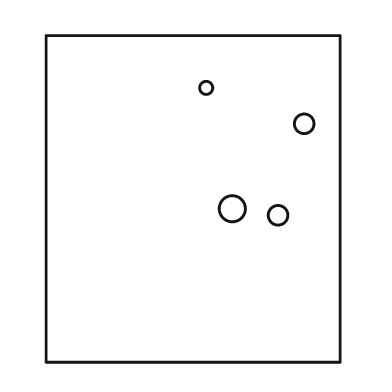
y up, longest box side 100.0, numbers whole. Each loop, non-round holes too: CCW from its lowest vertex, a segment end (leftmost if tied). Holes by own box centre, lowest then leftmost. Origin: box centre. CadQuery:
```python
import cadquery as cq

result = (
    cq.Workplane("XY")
    .moveTo(-45.0, -50.0)
    .lineTo(45.0, -50.0)
    .lineTo(45.0, 50.0)
    .lineTo(-45.0, 50.0)
    .close()
    .moveTo(26.0, -5.0)
    .circle(3.0)
    .moveTo(12.0, -3.0)
    .circle(4.0)
    .moveTo(34.0, 23.0)
    .circle(3.0)
    .moveTo(4.0, 34.0)
    .circle(2.0)
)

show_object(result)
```